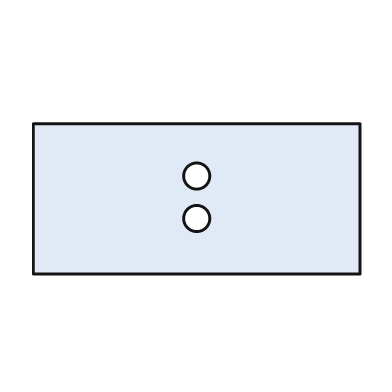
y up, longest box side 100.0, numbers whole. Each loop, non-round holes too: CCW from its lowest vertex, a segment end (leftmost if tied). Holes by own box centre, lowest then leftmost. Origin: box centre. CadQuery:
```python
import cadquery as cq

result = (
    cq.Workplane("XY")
    .moveTo(-50.0, -23.0)
    .lineTo(50.0, -23.0)
    .lineTo(50.0, 23.0)
    .lineTo(-50.0, 23.0)
    .close()
    .moveTo(0.0, -6.0)
    .circle(4.0)
    .moveTo(0.0, 7.0)
    .circle(4.0)
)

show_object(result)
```